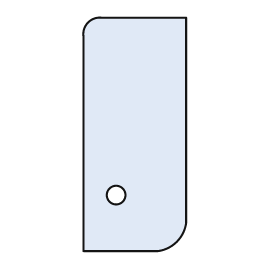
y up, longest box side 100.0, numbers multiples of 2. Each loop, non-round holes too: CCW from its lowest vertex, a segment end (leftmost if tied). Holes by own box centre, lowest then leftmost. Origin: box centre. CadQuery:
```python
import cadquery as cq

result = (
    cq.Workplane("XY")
    .moveTo(-22.0, -50.0)
    .lineTo(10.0, -50.0)
    .threePointArc((18.0, -46.0), (22.0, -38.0))
    .lineTo(22.0, 50.0)
    .lineTo(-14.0, 50.0)
    .threePointArc((-20.0, 48.0), (-22.0, 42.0))
    .close()
    .moveTo(-8.0, -26.0)
    .circle(4.0)
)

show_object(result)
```